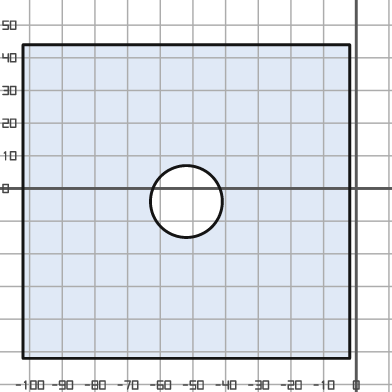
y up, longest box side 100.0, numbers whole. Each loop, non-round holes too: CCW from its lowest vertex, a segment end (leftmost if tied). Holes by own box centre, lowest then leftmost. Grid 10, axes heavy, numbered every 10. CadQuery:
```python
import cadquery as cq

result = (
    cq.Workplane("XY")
    .moveTo(-102.0, -52.0)
    .lineTo(-2.0, -52.0)
    .lineTo(-2.0, 44.0)
    .lineTo(-102.0, 44.0)
    .close()
    .moveTo(-52.0, -4.0)
    .circle(11.0)
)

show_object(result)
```